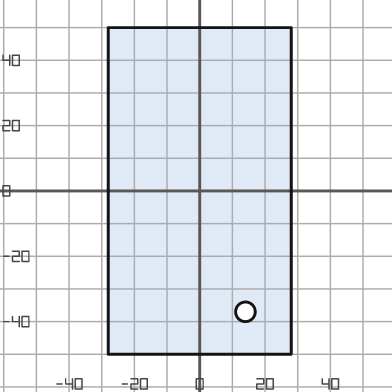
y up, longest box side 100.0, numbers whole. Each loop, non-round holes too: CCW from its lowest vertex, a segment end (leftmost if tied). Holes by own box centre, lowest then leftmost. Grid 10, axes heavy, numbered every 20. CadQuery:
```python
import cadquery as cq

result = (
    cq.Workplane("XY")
    .moveTo(-28.0, -50.0)
    .lineTo(28.0, -50.0)
    .lineTo(28.0, 50.0)
    .lineTo(-28.0, 50.0)
    .close()
    .moveTo(14.0, -37.0)
    .circle(3.0)
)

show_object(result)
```